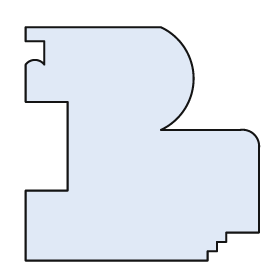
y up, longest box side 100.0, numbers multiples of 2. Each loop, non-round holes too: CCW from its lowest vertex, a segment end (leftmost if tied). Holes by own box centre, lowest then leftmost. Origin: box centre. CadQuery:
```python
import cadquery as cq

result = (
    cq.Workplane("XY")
    .moveTo(-50.0, -50.0)
    .lineTo(28.0, -50.0)
    .lineTo(28.0, -46.0)
    .lineTo(32.0, -46.0)
    .lineTo(32.0, -42.0)
    .lineTo(36.0, -42.0)
    .lineTo(36.0, -38.0)
    .lineTo(50.0, -38.0)
    .lineTo(50.0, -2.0)
    .threePointArc((48.0, 4.0), (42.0, 6.0))
    .lineTo(8.0, 6.0)
    .threePointArc((22.0, 28.0), (8.0, 50.0))
    .lineTo(-50.0, 50.0)
    .lineTo(-50.0, 44.0)
    .lineTo(-42.0, 44.0)
    .lineTo(-42.0, 34.0)
    .threePointArc((-46.0, 36.0), (-50.0, 34.0))
    .lineTo(-50.0, 18.0)
    .lineTo(-32.0, 18.0)
    .lineTo(-32.0, -20.0)
    .lineTo(-50.0, -20.0)
    .close()
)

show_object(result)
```